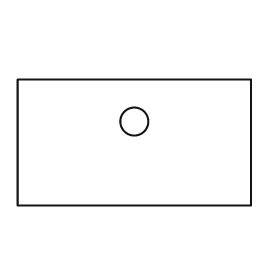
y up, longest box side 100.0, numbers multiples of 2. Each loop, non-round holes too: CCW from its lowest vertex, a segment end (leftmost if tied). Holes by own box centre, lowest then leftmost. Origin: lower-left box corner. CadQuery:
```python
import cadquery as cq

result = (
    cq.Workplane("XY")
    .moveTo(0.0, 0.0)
    .lineTo(100.0, 0.0)
    .lineTo(100.0, 54.0)
    .lineTo(0.0, 54.0)
    .close()
    .moveTo(50.0, 36.0)
    .circle(6.0)
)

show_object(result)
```